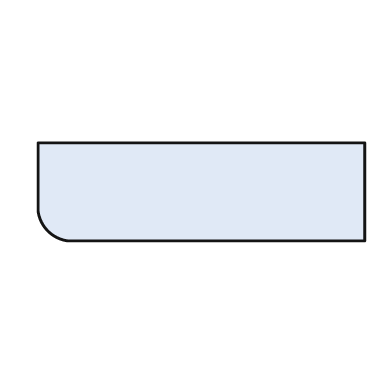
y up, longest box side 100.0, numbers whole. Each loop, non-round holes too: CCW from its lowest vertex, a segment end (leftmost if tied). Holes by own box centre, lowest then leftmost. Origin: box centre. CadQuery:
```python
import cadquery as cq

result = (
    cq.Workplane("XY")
    .moveTo(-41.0, -15.0)
    .lineTo(50.0, -15.0)
    .lineTo(50.0, 15.0)
    .lineTo(-50.0, 15.0)
    .lineTo(-50.0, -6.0)
    .threePointArc((-47.0, -12.0), (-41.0, -15.0))
    .close()
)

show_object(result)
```